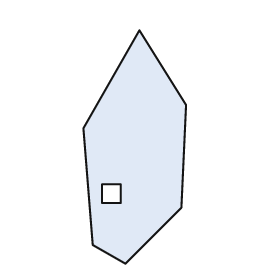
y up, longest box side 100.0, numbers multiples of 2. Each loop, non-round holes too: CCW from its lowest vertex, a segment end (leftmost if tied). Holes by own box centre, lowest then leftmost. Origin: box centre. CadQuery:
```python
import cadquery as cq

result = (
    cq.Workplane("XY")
    .moveTo(-4.0, -50.0)
    .lineTo(20.0, -26.0)
    .lineTo(22.0, 18.0)
    .lineTo(2.0, 50.0)
    .lineTo(-22.0, 8.0)
    .lineTo(-18.0, -42.0)
    .close()
    .moveTo(-14.0, -24.0)
    .lineTo(-6.0, -24.0)
    .lineTo(-6.0, -16.0)
    .lineTo(-14.0, -16.0)
    .close()
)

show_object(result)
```